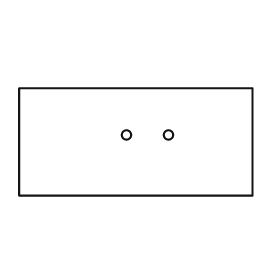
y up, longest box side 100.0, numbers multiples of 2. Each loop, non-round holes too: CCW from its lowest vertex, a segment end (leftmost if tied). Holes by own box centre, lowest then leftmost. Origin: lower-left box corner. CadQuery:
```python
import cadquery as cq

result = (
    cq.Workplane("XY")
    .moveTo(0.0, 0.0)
    .lineTo(100.0, 0.0)
    .lineTo(100.0, 46.0)
    .lineTo(0.0, 46.0)
    .close()
    .moveTo(46.0, 26.0)
    .circle(2.0)
    .moveTo(64.0, 26.0)
    .circle(2.0)
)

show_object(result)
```